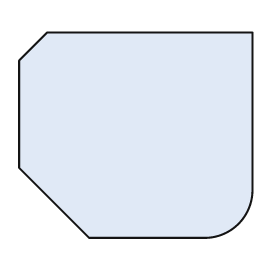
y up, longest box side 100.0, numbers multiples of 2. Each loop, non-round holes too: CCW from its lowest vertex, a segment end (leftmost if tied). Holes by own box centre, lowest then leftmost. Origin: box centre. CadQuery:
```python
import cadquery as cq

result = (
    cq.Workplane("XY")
    .moveTo(-20.0, -44.0)
    .lineTo(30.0, -44.0)
    .threePointArc((44.0, -38.0), (50.0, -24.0))
    .lineTo(50.0, 44.0)
    .lineTo(-38.0, 44.0)
    .lineTo(-50.0, 32.0)
    .lineTo(-50.0, -14.0)
    .close()
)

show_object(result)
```